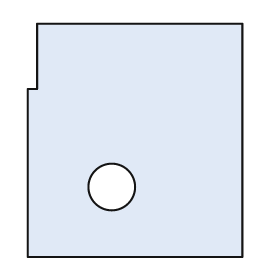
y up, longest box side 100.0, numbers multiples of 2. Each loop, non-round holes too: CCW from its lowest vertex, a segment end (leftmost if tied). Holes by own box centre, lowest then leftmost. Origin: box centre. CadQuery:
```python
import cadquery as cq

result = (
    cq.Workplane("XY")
    .moveTo(-46.0, -50.0)
    .lineTo(46.0, -50.0)
    .lineTo(46.0, 50.0)
    .lineTo(-42.0, 50.0)
    .lineTo(-42.0, 22.0)
    .lineTo(-46.0, 22.0)
    .close()
    .moveTo(-10.0, -20.0)
    .circle(10.0)
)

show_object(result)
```